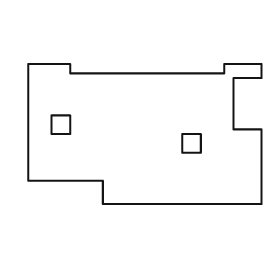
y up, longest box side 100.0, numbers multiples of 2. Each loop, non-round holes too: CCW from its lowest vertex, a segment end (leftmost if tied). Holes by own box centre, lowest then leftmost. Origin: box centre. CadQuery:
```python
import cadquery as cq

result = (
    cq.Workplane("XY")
    .moveTo(-18.0, -30.0)
    .lineTo(50.0, -30.0)
    .lineTo(50.0, 2.0)
    .lineTo(38.0, 2.0)
    .lineTo(38.0, 24.0)
    .lineTo(50.0, 24.0)
    .lineTo(50.0, 30.0)
    .lineTo(34.0, 30.0)
    .lineTo(34.0, 26.0)
    .lineTo(-32.0, 26.0)
    .lineTo(-32.0, 30.0)
    .lineTo(-50.0, 30.0)
    .lineTo(-50.0, -20.0)
    .lineTo(-18.0, -20.0)
    .close()
    .moveTo(16.0, -8.0)
    .lineTo(24.0, -8.0)
    .lineTo(24.0, 0.0)
    .lineTo(16.0, 0.0)
    .close()
    .moveTo(-40.0, 0.0)
    .lineTo(-32.0, 0.0)
    .lineTo(-32.0, 8.0)
    .lineTo(-40.0, 8.0)
    .close()
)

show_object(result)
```